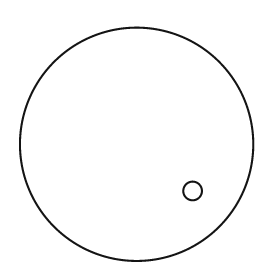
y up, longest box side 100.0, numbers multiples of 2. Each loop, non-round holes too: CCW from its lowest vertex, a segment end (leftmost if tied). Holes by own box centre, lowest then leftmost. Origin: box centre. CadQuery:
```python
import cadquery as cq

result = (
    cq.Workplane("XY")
    .moveTo(0.0, 0.0)
    .circle(50.0)
    .moveTo(24.0, -20.0)
    .circle(4.0)
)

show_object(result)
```